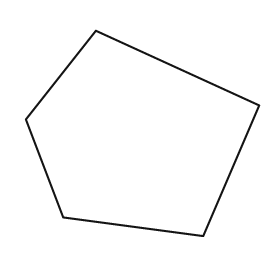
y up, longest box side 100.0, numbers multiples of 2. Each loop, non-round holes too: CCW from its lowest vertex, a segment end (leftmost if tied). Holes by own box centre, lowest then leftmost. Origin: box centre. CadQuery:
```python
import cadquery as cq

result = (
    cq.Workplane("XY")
    .moveTo(26.0, -44.0)
    .lineTo(50.0, 12.0)
    .lineTo(-20.0, 44.0)
    .lineTo(-50.0, 6.0)
    .lineTo(-34.0, -36.0)
    .close()
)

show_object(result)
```